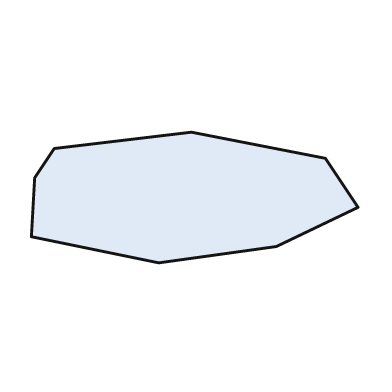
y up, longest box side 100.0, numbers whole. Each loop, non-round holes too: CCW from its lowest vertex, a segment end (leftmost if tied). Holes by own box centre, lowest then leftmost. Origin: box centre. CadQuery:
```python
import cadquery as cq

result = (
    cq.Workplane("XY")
    .moveTo(-11.0, -20.0)
    .lineTo(25.0, -15.0)
    .lineTo(50.0, -3.0)
    .lineTo(40.0, 12.0)
    .lineTo(-1.0, 20.0)
    .lineTo(-43.0, 15.0)
    .lineTo(-49.0, 6.0)
    .lineTo(-50.0, -12.0)
    .close()
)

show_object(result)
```